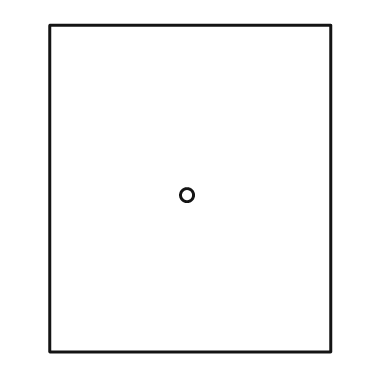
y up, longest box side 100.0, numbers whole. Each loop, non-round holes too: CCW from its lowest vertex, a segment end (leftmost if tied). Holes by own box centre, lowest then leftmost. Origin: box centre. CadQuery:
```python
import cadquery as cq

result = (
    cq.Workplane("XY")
    .moveTo(-43.0, -50.0)
    .lineTo(43.0, -50.0)
    .lineTo(43.0, 50.0)
    .lineTo(-43.0, 50.0)
    .close()
    .moveTo(-1.0, -2.0)
    .circle(2.0)
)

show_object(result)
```